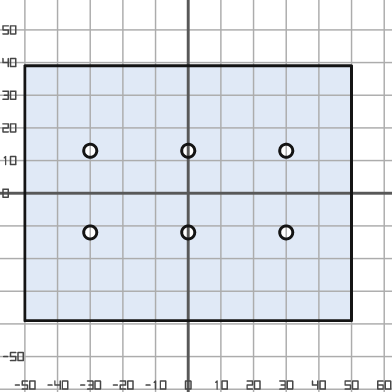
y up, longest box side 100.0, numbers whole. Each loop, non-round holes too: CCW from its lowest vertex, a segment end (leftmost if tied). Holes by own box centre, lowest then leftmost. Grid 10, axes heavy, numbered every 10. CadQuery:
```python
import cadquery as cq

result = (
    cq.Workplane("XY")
    .moveTo(-50.0, -39.0)
    .lineTo(50.0, -39.0)
    .lineTo(50.0, 39.0)
    .lineTo(-50.0, 39.0)
    .close()
    .moveTo(-30.0, -12.0)
    .circle(2.0)
    .moveTo(0.0, -12.0)
    .circle(2.0)
    .moveTo(30.0, -12.0)
    .circle(2.0)
    .moveTo(-30.0, 13.0)
    .circle(2.0)
    .moveTo(0.0, 13.0)
    .circle(2.0)
    .moveTo(30.0, 13.0)
    .circle(2.0)
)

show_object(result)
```